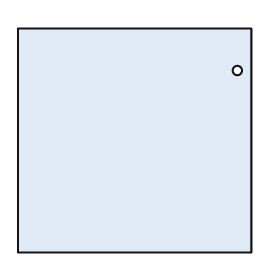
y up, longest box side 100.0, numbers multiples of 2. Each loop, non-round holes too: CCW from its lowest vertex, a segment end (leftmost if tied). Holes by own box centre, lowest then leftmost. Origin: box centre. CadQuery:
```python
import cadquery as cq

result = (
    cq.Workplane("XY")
    .moveTo(-50.0, -48.0)
    .lineTo(50.0, -48.0)
    .lineTo(50.0, 48.0)
    .lineTo(-50.0, 48.0)
    .close()
    .moveTo(44.0, 30.0)
    .circle(2.0)
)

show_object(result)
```